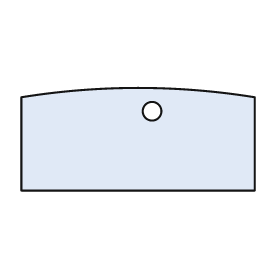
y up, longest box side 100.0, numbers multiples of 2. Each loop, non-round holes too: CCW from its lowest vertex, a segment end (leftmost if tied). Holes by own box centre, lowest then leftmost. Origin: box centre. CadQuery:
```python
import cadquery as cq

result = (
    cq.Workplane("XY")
    .moveTo(-50.0, -22.0)
    .lineTo(50.0, -22.0)
    .lineTo(50.0, 18.0)
    .threePointArc((0.0, 22.0), (-50.0, 18.0))
    .close()
    .moveTo(6.0, 12.0)
    .circle(4.0)
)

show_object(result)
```